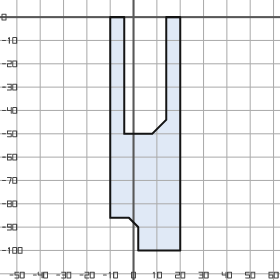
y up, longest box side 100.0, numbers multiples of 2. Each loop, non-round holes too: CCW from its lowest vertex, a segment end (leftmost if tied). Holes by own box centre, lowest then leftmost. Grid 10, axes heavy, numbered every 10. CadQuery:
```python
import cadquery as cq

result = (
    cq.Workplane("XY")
    .moveTo(2.0, -100.0)
    .lineTo(20.0, -100.0)
    .lineTo(20.0, 0.0)
    .lineTo(14.0, 0.0)
    .lineTo(14.0, -44.0)
    .lineTo(8.0, -50.0)
    .lineTo(-4.0, -50.0)
    .lineTo(-4.0, 0.0)
    .lineTo(-10.0, 0.0)
    .lineTo(-10.0, -86.0)
    .lineTo(-2.0, -86.0)
    .lineTo(2.0, -90.0)
    .close()
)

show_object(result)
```